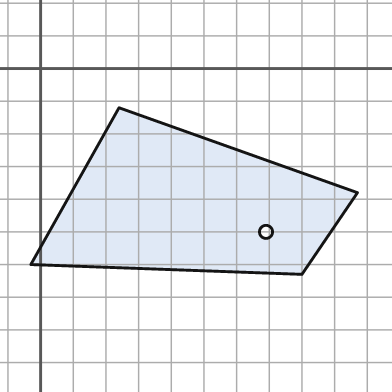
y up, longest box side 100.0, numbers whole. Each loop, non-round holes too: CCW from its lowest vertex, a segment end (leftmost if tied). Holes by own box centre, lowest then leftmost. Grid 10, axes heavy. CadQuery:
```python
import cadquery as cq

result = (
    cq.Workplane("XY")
    .moveTo(80.0, -63.0)
    .lineTo(97.0, -38.0)
    .lineTo(24.0, -12.0)
    .lineTo(-3.0, -60.0)
    .close()
    .moveTo(69.0, -50.0)
    .circle(2.0)
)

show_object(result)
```